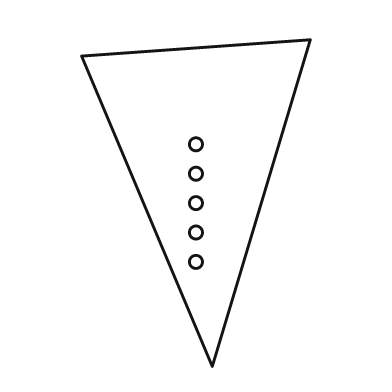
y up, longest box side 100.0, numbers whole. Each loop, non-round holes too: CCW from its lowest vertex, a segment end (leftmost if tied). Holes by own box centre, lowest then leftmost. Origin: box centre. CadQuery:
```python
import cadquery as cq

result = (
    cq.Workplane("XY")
    .moveTo(5.0, -50.0)
    .lineTo(35.0, 50.0)
    .lineTo(-35.0, 45.0)
    .close()
    .moveTo(0.0, -18.0)
    .circle(2.0)
    .moveTo(0.0, -9.0)
    .circle(2.0)
    .moveTo(0.0, 0.0)
    .circle(2.0)
    .moveTo(0.0, 9.0)
    .circle(2.0)
    .moveTo(0.0, 18.0)
    .circle(2.0)
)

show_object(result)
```